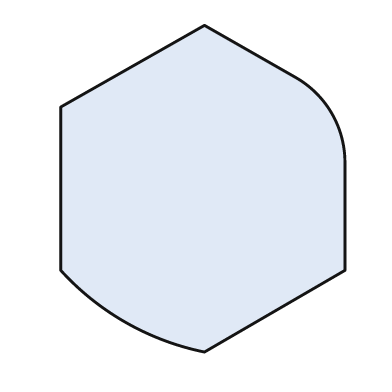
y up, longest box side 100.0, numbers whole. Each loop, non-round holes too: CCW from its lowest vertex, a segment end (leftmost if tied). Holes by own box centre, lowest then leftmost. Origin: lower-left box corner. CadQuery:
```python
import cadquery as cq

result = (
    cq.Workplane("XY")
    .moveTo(44.0, 0.0)
    .lineTo(87.0, 25.0)
    .lineTo(87.0, 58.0)
    .threePointArc((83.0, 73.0), (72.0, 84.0))
    .lineTo(44.0, 100.0)
    .lineTo(0.0, 75.0)
    .lineTo(0.0, 25.0)
    .threePointArc((20.0, 9.0), (44.0, 0.0))
    .close()
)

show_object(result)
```